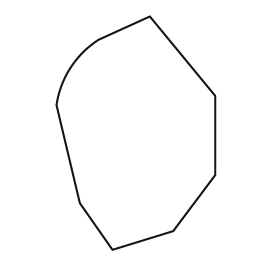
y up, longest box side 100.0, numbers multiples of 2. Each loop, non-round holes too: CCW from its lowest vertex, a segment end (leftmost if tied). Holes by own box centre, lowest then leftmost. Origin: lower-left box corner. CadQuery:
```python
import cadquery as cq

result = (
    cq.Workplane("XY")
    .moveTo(24.0, 0.0)
    .lineTo(50.0, 8.0)
    .lineTo(68.0, 32.0)
    .lineTo(68.0, 66.0)
    .lineTo(40.0, 100.0)
    .lineTo(18.0, 90.0)
    .threePointArc((6.0, 78.0), (0.0, 62.0))
    .lineTo(10.0, 20.0)
    .close()
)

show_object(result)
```